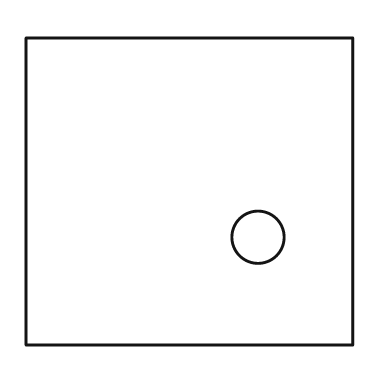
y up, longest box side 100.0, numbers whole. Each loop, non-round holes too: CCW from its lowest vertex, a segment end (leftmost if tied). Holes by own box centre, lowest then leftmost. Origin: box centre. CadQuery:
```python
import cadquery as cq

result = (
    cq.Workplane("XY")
    .moveTo(-50.0, -47.0)
    .lineTo(50.0, -47.0)
    .lineTo(50.0, 47.0)
    .lineTo(-50.0, 47.0)
    .close()
    .moveTo(21.0, -14.0)
    .circle(8.0)
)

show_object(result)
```